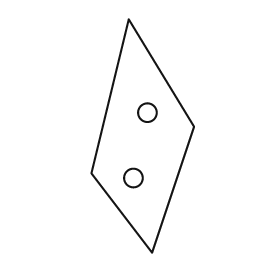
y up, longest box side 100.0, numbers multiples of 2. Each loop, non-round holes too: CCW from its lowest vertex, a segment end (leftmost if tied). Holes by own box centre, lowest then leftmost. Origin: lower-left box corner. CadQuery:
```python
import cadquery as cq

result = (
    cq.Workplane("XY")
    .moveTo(26.0, 0.0)
    .lineTo(44.0, 54.0)
    .lineTo(16.0, 100.0)
    .lineTo(0.0, 34.0)
    .close()
    .moveTo(18.0, 32.0)
    .circle(4.0)
    .moveTo(24.0, 60.0)
    .circle(4.0)
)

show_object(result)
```